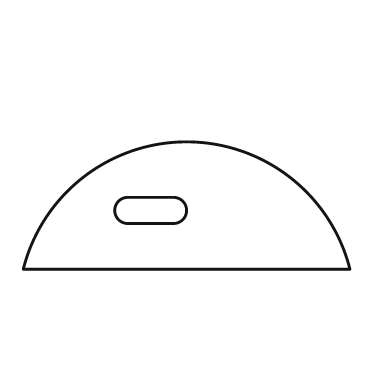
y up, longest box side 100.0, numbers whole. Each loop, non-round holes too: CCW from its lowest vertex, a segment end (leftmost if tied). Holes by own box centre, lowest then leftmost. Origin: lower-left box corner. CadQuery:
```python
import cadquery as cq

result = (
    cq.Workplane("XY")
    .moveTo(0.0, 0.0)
    .lineTo(100.0, 0.0)
    .threePointArc((50.0, 39.0), (0.0, 0.0))
    .close()
    .moveTo(32.0, 14.0)
    .lineTo(46.0, 14.0)
    .threePointArc((50.0, 18.0), (46.0, 22.0))
    .lineTo(32.0, 22.0)
    .threePointArc((28.0, 18.0), (32.0, 14.0))
    .close()
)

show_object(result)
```